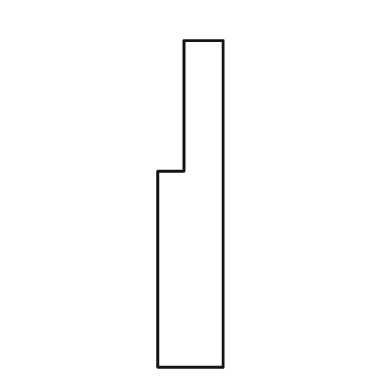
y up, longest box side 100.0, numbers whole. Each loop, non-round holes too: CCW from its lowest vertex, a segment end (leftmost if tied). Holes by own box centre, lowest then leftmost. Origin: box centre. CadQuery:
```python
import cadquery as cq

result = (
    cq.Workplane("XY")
    .moveTo(-10.0, -50.0)
    .lineTo(10.0, -50.0)
    .lineTo(10.0, 50.0)
    .lineTo(-2.0, 50.0)
    .lineTo(-2.0, 10.0)
    .lineTo(-10.0, 10.0)
    .close()
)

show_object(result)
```